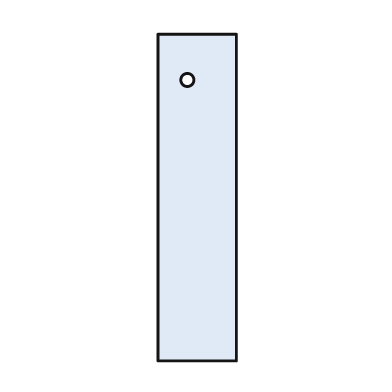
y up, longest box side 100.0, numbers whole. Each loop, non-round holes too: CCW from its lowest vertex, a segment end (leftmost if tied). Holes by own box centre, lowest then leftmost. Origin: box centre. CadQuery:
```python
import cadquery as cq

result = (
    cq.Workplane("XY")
    .moveTo(-12.0, -50.0)
    .lineTo(12.0, -50.0)
    .lineTo(12.0, 50.0)
    .lineTo(-12.0, 50.0)
    .close()
    .moveTo(-3.0, 36.0)
    .circle(2.0)
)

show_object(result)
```